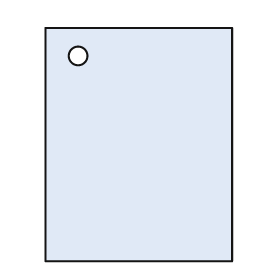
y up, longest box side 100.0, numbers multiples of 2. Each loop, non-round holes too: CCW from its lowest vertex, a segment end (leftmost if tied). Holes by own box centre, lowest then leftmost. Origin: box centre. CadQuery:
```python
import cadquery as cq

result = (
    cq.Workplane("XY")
    .moveTo(-40.0, -50.0)
    .lineTo(40.0, -50.0)
    .lineTo(40.0, 50.0)
    .lineTo(-40.0, 50.0)
    .close()
    .moveTo(-26.0, 38.0)
    .circle(4.0)
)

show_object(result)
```